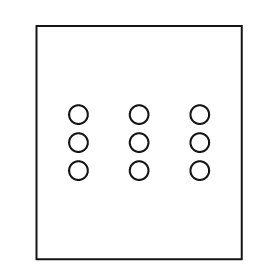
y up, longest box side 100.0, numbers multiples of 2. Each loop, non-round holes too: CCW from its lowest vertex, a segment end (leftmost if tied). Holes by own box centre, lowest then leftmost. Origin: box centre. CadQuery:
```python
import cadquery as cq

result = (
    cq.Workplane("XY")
    .moveTo(-44.0, -50.0)
    .lineTo(44.0, -50.0)
    .lineTo(44.0, 50.0)
    .lineTo(-44.0, 50.0)
    .close()
    .moveTo(-26.0, -12.0)
    .circle(4.0)
    .moveTo(0.0, -12.0)
    .circle(4.0)
    .moveTo(26.0, -12.0)
    .circle(4.0)
    .moveTo(-26.0, 0.0)
    .circle(4.0)
    .moveTo(0.0, 0.0)
    .circle(4.0)
    .moveTo(26.0, 0.0)
    .circle(4.0)
    .moveTo(-26.0, 12.0)
    .circle(4.0)
    .moveTo(0.0, 12.0)
    .circle(4.0)
    .moveTo(26.0, 12.0)
    .circle(4.0)
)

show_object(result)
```